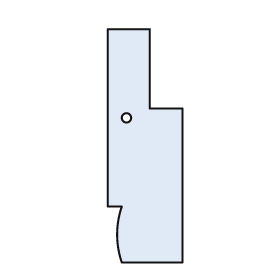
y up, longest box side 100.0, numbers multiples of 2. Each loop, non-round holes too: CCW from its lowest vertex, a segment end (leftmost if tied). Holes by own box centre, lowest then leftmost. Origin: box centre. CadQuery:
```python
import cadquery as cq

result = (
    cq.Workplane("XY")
    .moveTo(-10.0, -50.0)
    .lineTo(16.0, -50.0)
    .lineTo(16.0, 16.0)
    .lineTo(2.0, 16.0)
    .lineTo(2.0, 50.0)
    .lineTo(-16.0, 50.0)
    .lineTo(-16.0, -26.0)
    .lineTo(-10.0, -26.0)
    .threePointArc((-12.0, -38.0), (-10.0, -50.0))
    .close()
    .moveTo(-8.0, 12.0)
    .circle(2.0)
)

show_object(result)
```